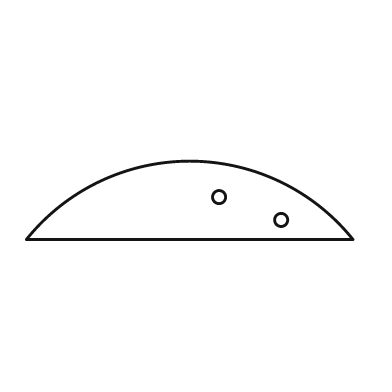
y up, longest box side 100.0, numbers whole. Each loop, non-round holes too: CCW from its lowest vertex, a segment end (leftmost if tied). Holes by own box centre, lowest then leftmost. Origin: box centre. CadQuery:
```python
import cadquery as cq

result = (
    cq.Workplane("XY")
    .moveTo(-50.0, -12.0)
    .lineTo(50.0, -12.0)
    .threePointArc((0.0, 12.0), (-50.0, -12.0))
    .close()
    .moveTo(28.0, -6.0)
    .circle(2.0)
    .moveTo(9.0, 1.0)
    .circle(2.0)
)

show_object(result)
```